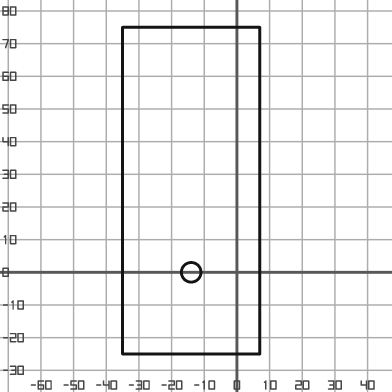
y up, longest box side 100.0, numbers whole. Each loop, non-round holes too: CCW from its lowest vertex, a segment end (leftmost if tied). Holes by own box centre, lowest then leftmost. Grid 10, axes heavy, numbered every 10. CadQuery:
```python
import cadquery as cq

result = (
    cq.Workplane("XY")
    .moveTo(-35.0, -25.0)
    .lineTo(7.0, -25.0)
    .lineTo(7.0, 75.0)
    .lineTo(-35.0, 75.0)
    .close()
    .moveTo(-14.0, 0.0)
    .circle(3.0)
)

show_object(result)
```